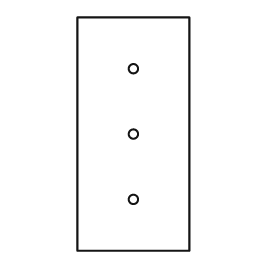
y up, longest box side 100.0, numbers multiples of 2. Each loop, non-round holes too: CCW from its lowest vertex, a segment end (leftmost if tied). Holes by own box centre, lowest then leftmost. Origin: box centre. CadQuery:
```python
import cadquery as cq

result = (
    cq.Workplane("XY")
    .moveTo(-24.0, -50.0)
    .lineTo(24.0, -50.0)
    .lineTo(24.0, 50.0)
    .lineTo(-24.0, 50.0)
    .close()
    .moveTo(0.0, -28.0)
    .circle(2.0)
    .moveTo(0.0, 0.0)
    .circle(2.0)
    .moveTo(0.0, 28.0)
    .circle(2.0)
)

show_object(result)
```